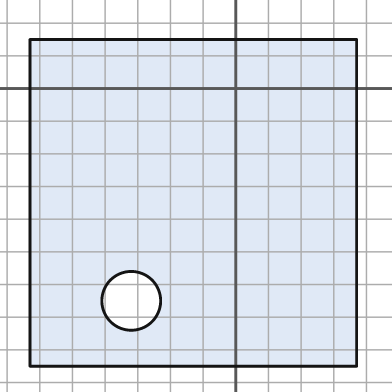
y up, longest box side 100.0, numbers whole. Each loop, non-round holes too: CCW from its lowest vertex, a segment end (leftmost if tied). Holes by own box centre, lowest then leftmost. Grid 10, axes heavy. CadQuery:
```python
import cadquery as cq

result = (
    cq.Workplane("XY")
    .moveTo(-63.0, -85.0)
    .lineTo(37.0, -85.0)
    .lineTo(37.0, 15.0)
    .lineTo(-63.0, 15.0)
    .close()
    .moveTo(-32.0, -65.0)
    .circle(9.0)
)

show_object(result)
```